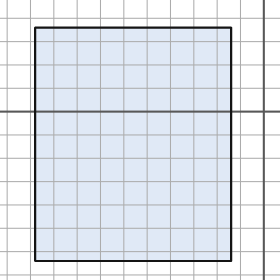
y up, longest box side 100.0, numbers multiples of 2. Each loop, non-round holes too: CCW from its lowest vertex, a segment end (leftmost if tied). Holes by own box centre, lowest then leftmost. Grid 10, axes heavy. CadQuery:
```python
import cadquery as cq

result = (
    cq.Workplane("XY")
    .moveTo(-98.0, -64.0)
    .lineTo(-14.0, -64.0)
    .lineTo(-14.0, 36.0)
    .lineTo(-98.0, 36.0)
    .close()
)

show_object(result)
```